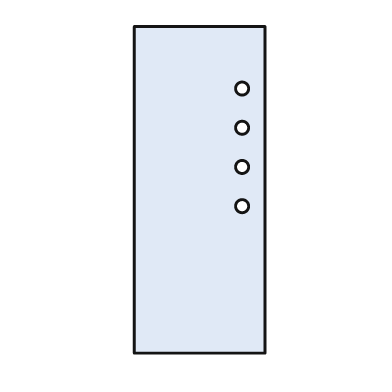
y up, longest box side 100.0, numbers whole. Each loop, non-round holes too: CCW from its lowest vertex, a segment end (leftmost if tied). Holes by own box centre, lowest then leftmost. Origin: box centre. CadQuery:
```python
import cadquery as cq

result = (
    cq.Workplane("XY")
    .moveTo(-20.0, -50.0)
    .lineTo(20.0, -50.0)
    .lineTo(20.0, 50.0)
    .lineTo(-20.0, 50.0)
    .close()
    .moveTo(13.0, -5.0)
    .circle(2.0)
    .moveTo(13.0, 7.0)
    .circle(2.0)
    .moveTo(13.0, 19.0)
    .circle(2.0)
    .moveTo(13.0, 31.0)
    .circle(2.0)
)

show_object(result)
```